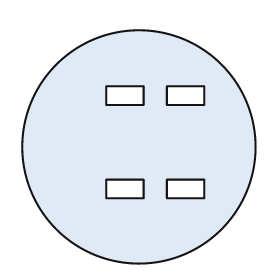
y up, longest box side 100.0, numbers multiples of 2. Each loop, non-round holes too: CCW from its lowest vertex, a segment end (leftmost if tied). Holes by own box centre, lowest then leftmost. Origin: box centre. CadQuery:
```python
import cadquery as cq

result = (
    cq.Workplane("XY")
    .moveTo(0.0, 0.0)
    .circle(50.0)
    .moveTo(-14.0, -22.0)
    .lineTo(2.0, -22.0)
    .lineTo(2.0, -14.0)
    .lineTo(-14.0, -14.0)
    .close()
    .moveTo(12.0, -22.0)
    .lineTo(28.0, -22.0)
    .lineTo(28.0, -14.0)
    .lineTo(12.0, -14.0)
    .close()
    .moveTo(-14.0, 18.0)
    .lineTo(2.0, 18.0)
    .lineTo(2.0, 26.0)
    .lineTo(-14.0, 26.0)
    .close()
    .moveTo(12.0, 18.0)
    .lineTo(28.0, 18.0)
    .lineTo(28.0, 26.0)
    .lineTo(12.0, 26.0)
    .close()
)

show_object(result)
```